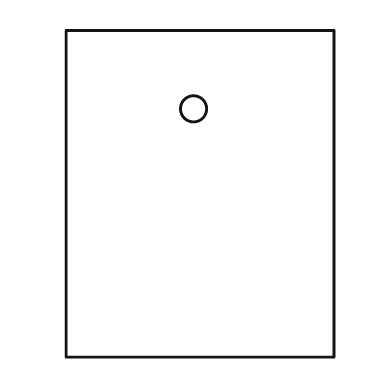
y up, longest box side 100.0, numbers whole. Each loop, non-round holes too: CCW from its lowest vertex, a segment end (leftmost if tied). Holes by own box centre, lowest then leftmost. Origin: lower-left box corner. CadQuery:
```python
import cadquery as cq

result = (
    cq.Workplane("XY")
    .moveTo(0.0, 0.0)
    .lineTo(82.0, 0.0)
    .lineTo(82.0, 100.0)
    .lineTo(0.0, 100.0)
    .close()
    .moveTo(39.0, 76.0)
    .circle(4.0)
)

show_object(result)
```